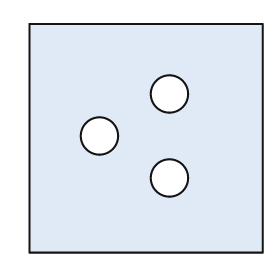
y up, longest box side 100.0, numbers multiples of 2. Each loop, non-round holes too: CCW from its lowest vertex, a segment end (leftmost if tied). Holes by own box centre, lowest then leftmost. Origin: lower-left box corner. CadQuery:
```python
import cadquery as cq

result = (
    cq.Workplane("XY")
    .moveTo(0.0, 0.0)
    .lineTo(100.0, 0.0)
    .lineTo(100.0, 98.0)
    .lineTo(0.0, 98.0)
    .close()
    .moveTo(60.0, 32.0)
    .circle(8.0)
    .moveTo(30.0, 50.0)
    .circle(8.0)
    .moveTo(60.0, 68.0)
    .circle(8.0)
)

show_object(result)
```